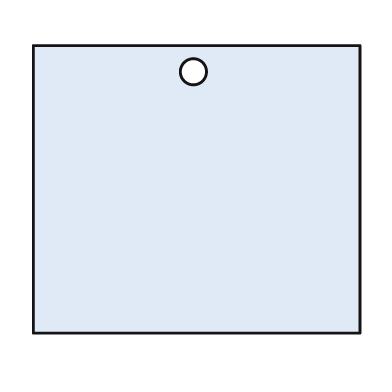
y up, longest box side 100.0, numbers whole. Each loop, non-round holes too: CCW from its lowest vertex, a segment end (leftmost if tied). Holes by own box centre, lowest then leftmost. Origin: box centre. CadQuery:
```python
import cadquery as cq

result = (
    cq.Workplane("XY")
    .moveTo(-50.0, -44.0)
    .lineTo(50.0, -44.0)
    .lineTo(50.0, 44.0)
    .lineTo(-50.0, 44.0)
    .close()
    .moveTo(-1.0, 36.0)
    .circle(4.0)
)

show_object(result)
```